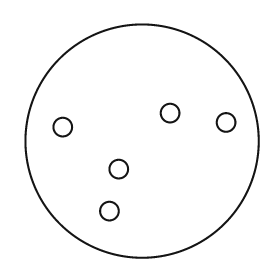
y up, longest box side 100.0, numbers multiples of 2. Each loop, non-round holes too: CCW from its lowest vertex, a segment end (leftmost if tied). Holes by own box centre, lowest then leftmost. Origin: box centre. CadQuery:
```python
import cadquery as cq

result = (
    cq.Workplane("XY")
    .moveTo(0.0, 0.0)
    .circle(50.0)
    .moveTo(-14.0, -30.0)
    .circle(4.0)
    .moveTo(-10.0, -12.0)
    .circle(4.0)
    .moveTo(-34.0, 6.0)
    .circle(4.0)
    .moveTo(36.0, 8.0)
    .circle(4.0)
    .moveTo(12.0, 12.0)
    .circle(4.0)
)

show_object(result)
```